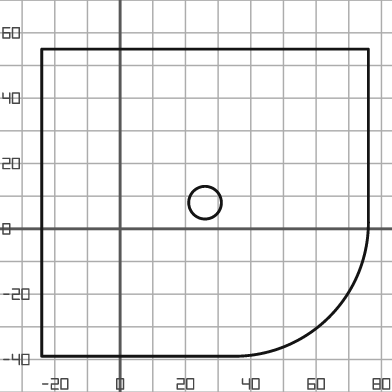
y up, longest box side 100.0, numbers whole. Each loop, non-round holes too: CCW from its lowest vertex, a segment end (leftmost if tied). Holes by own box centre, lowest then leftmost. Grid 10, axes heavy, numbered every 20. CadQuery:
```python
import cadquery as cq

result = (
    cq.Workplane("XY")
    .moveTo(-24.0, -39.0)
    .lineTo(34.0, -39.0)
    .threePointArc((64.0, -27.0), (76.0, 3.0))
    .lineTo(76.0, 55.0)
    .lineTo(-24.0, 55.0)
    .close()
    .moveTo(26.0, 8.0)
    .circle(5.0)
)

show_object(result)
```